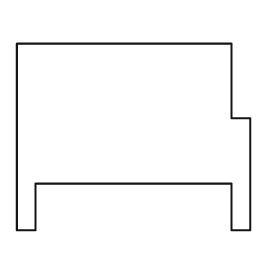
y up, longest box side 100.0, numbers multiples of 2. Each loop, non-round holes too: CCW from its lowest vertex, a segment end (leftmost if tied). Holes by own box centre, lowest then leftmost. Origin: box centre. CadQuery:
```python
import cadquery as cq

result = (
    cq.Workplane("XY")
    .moveTo(-50.0, -40.0)
    .lineTo(-42.0, -40.0)
    .lineTo(-42.0, -20.0)
    .lineTo(42.0, -20.0)
    .lineTo(42.0, -40.0)
    .lineTo(50.0, -40.0)
    .lineTo(50.0, 8.0)
    .lineTo(42.0, 8.0)
    .lineTo(42.0, 40.0)
    .lineTo(-50.0, 40.0)
    .close()
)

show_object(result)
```